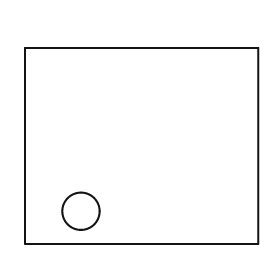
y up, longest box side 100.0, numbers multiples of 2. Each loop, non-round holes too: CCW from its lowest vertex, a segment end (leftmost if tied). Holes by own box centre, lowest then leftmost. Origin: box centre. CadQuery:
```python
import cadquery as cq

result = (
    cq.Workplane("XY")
    .moveTo(-50.0, -42.0)
    .lineTo(50.0, -42.0)
    .lineTo(50.0, 42.0)
    .lineTo(-50.0, 42.0)
    .close()
    .moveTo(-26.0, -28.0)
    .circle(8.0)
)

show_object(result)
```